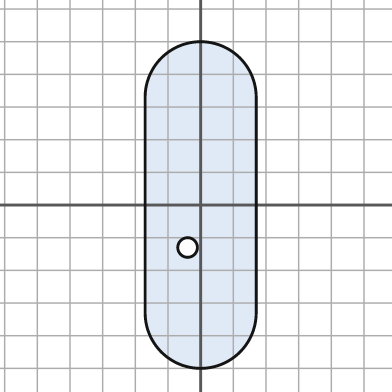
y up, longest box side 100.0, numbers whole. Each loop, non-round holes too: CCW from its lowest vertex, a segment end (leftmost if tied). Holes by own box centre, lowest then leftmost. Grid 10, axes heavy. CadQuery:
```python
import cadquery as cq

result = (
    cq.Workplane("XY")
    .moveTo(-17.0, -33.0)
    .threePointArc((0.0, -50.0), (17.0, -33.0))
    .lineTo(17.0, 33.0)
    .threePointArc((0.0, 50.0), (-17.0, 33.0))
    .close()
    .moveTo(-4.0, -13.0)
    .circle(3.0)
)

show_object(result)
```